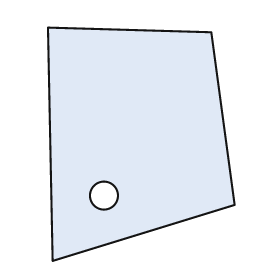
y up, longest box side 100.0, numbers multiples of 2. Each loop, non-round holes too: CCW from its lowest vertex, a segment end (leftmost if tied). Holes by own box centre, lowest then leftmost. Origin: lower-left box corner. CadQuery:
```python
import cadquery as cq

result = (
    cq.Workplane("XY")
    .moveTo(2.0, 0.0)
    .lineTo(80.0, 24.0)
    .lineTo(70.0, 98.0)
    .lineTo(0.0, 100.0)
    .close()
    .moveTo(24.0, 28.0)
    .circle(6.0)
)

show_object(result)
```